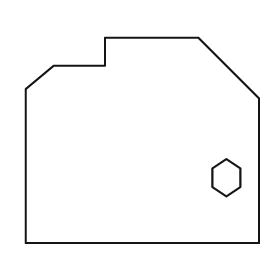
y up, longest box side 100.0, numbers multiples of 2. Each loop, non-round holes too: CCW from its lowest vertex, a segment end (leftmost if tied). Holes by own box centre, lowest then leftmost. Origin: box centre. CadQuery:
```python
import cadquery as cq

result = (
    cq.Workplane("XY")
    .moveTo(-50.0, -44.0)
    .lineTo(50.0, -44.0)
    .lineTo(50.0, 18.0)
    .lineTo(24.0, 44.0)
    .lineTo(-16.0, 44.0)
    .lineTo(-16.0, 32.0)
    .lineTo(-38.0, 32.0)
    .lineTo(-50.0, 22.0)
    .close()
    .moveTo(36.0, -24.0)
    .lineTo(42.0, -20.0)
    .lineTo(42.0, -12.0)
    .lineTo(36.0, -8.0)
    .lineTo(30.0, -12.0)
    .lineTo(30.0, -20.0)
    .close()
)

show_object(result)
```